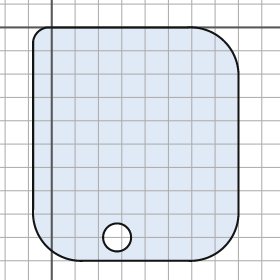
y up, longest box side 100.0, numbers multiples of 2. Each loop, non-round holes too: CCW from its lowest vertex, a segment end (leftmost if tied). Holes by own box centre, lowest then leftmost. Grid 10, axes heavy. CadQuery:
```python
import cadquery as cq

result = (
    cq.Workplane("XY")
    .moveTo(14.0, -100.0)
    .lineTo(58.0, -100.0)
    .threePointArc((74.0, -94.0), (80.0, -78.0))
    .lineTo(80.0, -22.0)
    .threePointArc((74.0, -6.0), (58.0, 0.0))
    .lineTo(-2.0, 0.0)
    .threePointArc((-6.0, -2.0), (-8.0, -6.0))
    .lineTo(-8.0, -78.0)
    .threePointArc((-2.0, -94.0), (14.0, -100.0))
    .close()
    .moveTo(28.0, -90.0)
    .circle(6.0)
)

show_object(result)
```